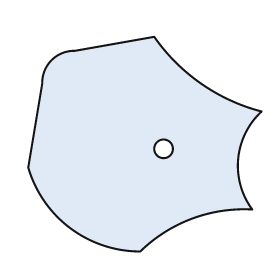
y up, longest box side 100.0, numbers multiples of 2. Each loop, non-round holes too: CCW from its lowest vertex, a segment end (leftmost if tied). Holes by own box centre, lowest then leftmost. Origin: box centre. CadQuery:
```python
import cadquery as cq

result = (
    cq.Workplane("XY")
    .moveTo(-2.0, -46.0)
    .threePointArc((20.0, -32.0), (46.0, -28.0))
    .threePointArc((40.0, -6.0), (50.0, 14.0))
    .threePointArc((24.0, 26.0), (4.0, 46.0))
    .lineTo(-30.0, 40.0)
    .threePointArc((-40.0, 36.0), (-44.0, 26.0))
    .lineTo(-50.0, -10.0)
    .threePointArc((-32.0, -36.0), (-2.0, -46.0))
    .close()
    .moveTo(8.0, -2.0)
    .circle(4.0)
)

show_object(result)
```